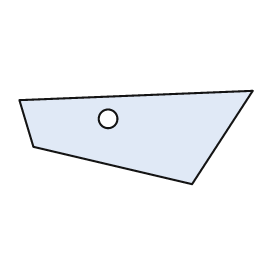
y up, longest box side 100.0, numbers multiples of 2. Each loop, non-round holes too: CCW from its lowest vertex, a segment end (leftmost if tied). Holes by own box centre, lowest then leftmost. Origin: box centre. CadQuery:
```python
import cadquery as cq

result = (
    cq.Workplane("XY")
    .moveTo(24.0, -20.0)
    .lineTo(50.0, 20.0)
    .lineTo(-50.0, 16.0)
    .lineTo(-44.0, -4.0)
    .close()
    .moveTo(-12.0, 8.0)
    .circle(4.0)
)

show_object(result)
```